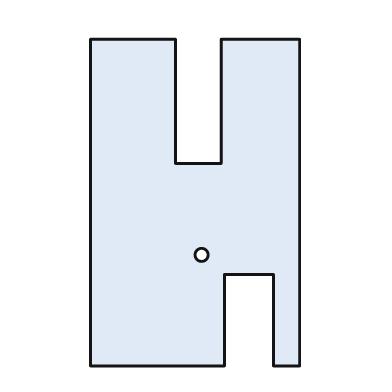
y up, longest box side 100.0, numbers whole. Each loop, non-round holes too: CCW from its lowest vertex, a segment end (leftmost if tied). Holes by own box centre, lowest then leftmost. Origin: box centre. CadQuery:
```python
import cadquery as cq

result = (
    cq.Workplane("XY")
    .moveTo(-32.0, -50.0)
    .lineTo(9.0, -50.0)
    .lineTo(9.0, -22.0)
    .lineTo(24.0, -22.0)
    .lineTo(24.0, -50.0)
    .lineTo(32.0, -50.0)
    .lineTo(32.0, 50.0)
    .lineTo(8.0, 50.0)
    .lineTo(8.0, 12.0)
    .lineTo(-6.0, 12.0)
    .lineTo(-6.0, 50.0)
    .lineTo(-32.0, 50.0)
    .close()
    .moveTo(2.0, -16.0)
    .circle(2.0)
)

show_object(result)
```